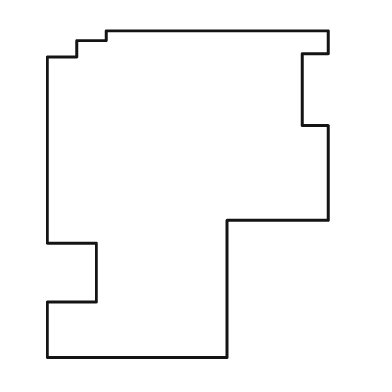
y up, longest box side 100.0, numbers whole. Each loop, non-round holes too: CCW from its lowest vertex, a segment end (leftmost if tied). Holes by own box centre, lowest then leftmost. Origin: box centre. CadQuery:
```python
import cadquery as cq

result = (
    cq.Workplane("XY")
    .moveTo(-43.0, -50.0)
    .lineTo(12.0, -50.0)
    .lineTo(12.0, -8.0)
    .lineTo(43.0, -8.0)
    .lineTo(43.0, 21.0)
    .lineTo(35.0, 21.0)
    .lineTo(35.0, 43.0)
    .lineTo(43.0, 43.0)
    .lineTo(43.0, 50.0)
    .lineTo(-25.0, 50.0)
    .lineTo(-25.0, 47.0)
    .lineTo(-34.0, 47.0)
    .lineTo(-34.0, 42.0)
    .lineTo(-43.0, 42.0)
    .lineTo(-43.0, -15.0)
    .lineTo(-28.0, -15.0)
    .lineTo(-28.0, -33.0)
    .lineTo(-43.0, -33.0)
    .close()
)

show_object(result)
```